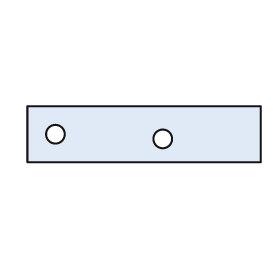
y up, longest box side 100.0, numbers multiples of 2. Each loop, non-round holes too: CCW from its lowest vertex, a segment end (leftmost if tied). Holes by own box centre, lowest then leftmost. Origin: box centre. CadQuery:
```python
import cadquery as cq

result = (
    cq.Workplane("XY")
    .moveTo(-50.0, -12.0)
    .lineTo(50.0, -12.0)
    .lineTo(50.0, 12.0)
    .lineTo(-50.0, 12.0)
    .close()
    .moveTo(8.0, -2.0)
    .circle(4.0)
    .moveTo(-38.0, 0.0)
    .circle(4.0)
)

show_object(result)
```